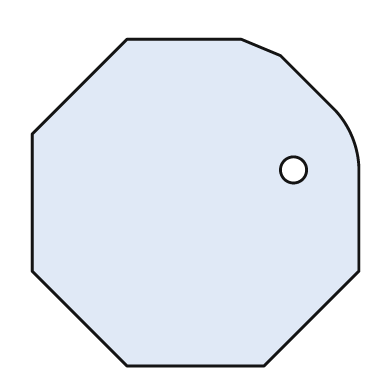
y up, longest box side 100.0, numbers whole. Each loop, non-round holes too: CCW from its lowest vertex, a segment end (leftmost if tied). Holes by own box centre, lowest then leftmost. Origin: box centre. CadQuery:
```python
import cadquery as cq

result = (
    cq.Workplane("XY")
    .moveTo(-21.0, -50.0)
    .lineTo(21.0, -50.0)
    .lineTo(50.0, -21.0)
    .lineTo(50.0, 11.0)
    .threePointArc((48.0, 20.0), (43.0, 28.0))
    .lineTo(26.0, 45.0)
    .lineTo(14.0, 50.0)
    .lineTo(-21.0, 50.0)
    .lineTo(-50.0, 21.0)
    .lineTo(-50.0, -21.0)
    .close()
    .moveTo(30.0, 10.0)
    .circle(4.0)
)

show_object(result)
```